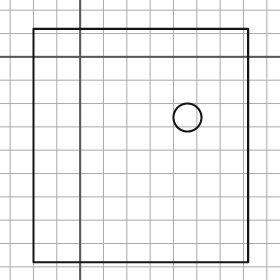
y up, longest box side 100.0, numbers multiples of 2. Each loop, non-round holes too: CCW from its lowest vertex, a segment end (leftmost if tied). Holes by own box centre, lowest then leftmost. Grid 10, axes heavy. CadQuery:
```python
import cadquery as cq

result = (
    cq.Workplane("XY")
    .moveTo(-20.0, -88.0)
    .lineTo(72.0, -88.0)
    .lineTo(72.0, 12.0)
    .lineTo(-20.0, 12.0)
    .close()
    .moveTo(46.0, -26.0)
    .circle(6.0)
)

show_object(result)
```